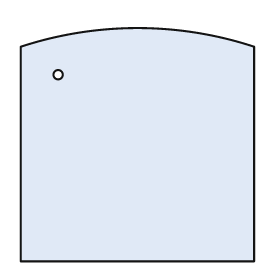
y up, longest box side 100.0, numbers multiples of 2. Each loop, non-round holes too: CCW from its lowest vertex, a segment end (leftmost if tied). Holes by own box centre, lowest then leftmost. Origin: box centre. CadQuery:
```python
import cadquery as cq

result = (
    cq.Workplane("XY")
    .moveTo(-50.0, -50.0)
    .lineTo(50.0, -50.0)
    .lineTo(50.0, 42.0)
    .threePointArc((0.0, 50.0), (-50.0, 42.0))
    .close()
    .moveTo(-34.0, 30.0)
    .circle(2.0)
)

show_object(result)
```